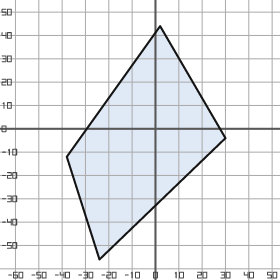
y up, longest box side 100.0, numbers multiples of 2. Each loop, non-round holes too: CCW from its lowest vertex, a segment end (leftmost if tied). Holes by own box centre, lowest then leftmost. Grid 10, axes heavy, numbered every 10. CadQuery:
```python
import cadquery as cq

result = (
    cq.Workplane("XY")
    .moveTo(-24.0, -56.0)
    .lineTo(30.0, -4.0)
    .lineTo(2.0, 44.0)
    .lineTo(-38.0, -12.0)
    .close()
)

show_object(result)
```